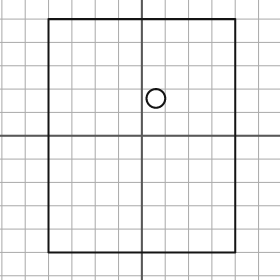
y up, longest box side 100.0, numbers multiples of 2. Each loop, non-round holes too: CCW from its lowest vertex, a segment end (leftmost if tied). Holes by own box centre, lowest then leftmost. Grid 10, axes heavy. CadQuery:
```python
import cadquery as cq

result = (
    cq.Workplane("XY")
    .moveTo(-40.0, -50.0)
    .lineTo(40.0, -50.0)
    .lineTo(40.0, 50.0)
    .lineTo(-40.0, 50.0)
    .close()
    .moveTo(6.0, 16.0)
    .circle(4.0)
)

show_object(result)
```